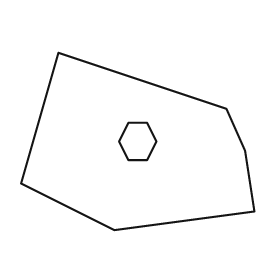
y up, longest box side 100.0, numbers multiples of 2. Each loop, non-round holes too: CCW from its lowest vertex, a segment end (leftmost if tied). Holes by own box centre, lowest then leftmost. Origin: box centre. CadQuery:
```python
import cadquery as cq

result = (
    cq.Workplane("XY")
    .moveTo(-10.0, -38.0)
    .lineTo(50.0, -30.0)
    .lineTo(46.0, -4.0)
    .lineTo(38.0, 14.0)
    .lineTo(-34.0, 38.0)
    .lineTo(-50.0, -18.0)
    .close()
    .moveTo(-4.0, -8.0)
    .lineTo(4.0, -8.0)
    .lineTo(8.0, 0.0)
    .lineTo(4.0, 8.0)
    .lineTo(-4.0, 8.0)
    .lineTo(-8.0, 0.0)
    .close()
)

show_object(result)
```